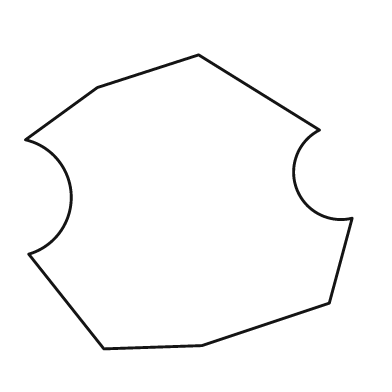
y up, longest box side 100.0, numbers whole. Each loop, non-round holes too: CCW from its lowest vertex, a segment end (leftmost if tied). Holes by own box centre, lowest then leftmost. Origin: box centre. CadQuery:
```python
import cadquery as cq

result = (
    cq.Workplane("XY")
    .moveTo(-26.0, -45.0)
    .lineTo(4.0, -44.0)
    .lineTo(43.0, -31.0)
    .lineTo(50.0, -5.0)
    .threePointArc((33.0, 4.0), (40.0, 22.0))
    .lineTo(3.0, 45.0)
    .lineTo(-28.0, 35.0)
    .lineTo(-50.0, 19.0)
    .threePointArc((-36.0, 2.0), (-49.0, -16.0))
    .close()
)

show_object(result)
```